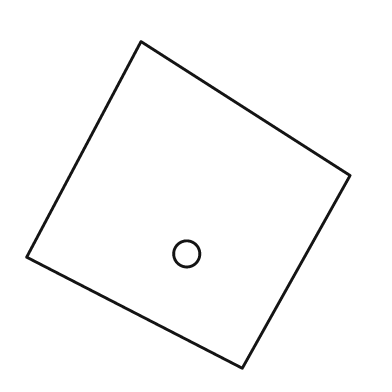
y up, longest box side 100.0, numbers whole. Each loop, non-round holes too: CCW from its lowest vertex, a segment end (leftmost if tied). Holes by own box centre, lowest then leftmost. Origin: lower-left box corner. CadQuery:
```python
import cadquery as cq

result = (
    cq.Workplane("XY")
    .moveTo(66.0, 0.0)
    .lineTo(99.0, 59.0)
    .lineTo(35.0, 100.0)
    .lineTo(0.0, 34.0)
    .close()
    .moveTo(49.0, 35.0)
    .circle(4.0)
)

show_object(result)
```